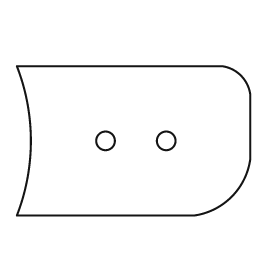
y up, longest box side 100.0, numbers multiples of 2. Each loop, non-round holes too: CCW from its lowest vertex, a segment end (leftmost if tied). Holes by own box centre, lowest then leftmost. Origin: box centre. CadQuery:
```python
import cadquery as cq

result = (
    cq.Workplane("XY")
    .moveTo(-50.0, -32.0)
    .lineTo(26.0, -32.0)
    .threePointArc((42.0, -24.0), (50.0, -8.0))
    .lineTo(50.0, 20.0)
    .threePointArc((46.0, 28.0), (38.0, 32.0))
    .lineTo(-50.0, 32.0)
    .threePointArc((-44.0, 0.0), (-50.0, -32.0))
    .close()
    .moveTo(-12.0, 0.0)
    .circle(4.0)
    .moveTo(14.0, 0.0)
    .circle(4.0)
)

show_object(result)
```